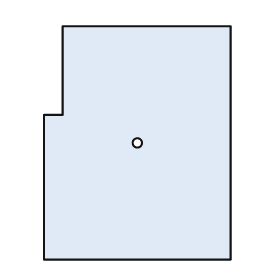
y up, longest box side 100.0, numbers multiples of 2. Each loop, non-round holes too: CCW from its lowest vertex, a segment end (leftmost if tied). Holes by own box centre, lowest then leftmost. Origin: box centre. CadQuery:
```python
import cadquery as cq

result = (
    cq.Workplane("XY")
    .moveTo(-40.0, -50.0)
    .lineTo(40.0, -50.0)
    .lineTo(40.0, 50.0)
    .lineTo(-32.0, 50.0)
    .lineTo(-32.0, 12.0)
    .lineTo(-40.0, 12.0)
    .close()
    .moveTo(0.0, 0.0)
    .circle(2.0)
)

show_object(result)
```